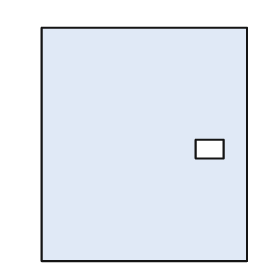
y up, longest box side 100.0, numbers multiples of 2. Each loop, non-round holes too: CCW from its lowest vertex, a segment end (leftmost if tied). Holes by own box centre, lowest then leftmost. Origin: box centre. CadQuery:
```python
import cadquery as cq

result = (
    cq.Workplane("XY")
    .moveTo(-44.0, -50.0)
    .lineTo(44.0, -50.0)
    .lineTo(44.0, 50.0)
    .lineTo(-44.0, 50.0)
    .close()
    .moveTo(22.0, -6.0)
    .lineTo(34.0, -6.0)
    .lineTo(34.0, 2.0)
    .lineTo(22.0, 2.0)
    .close()
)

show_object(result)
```